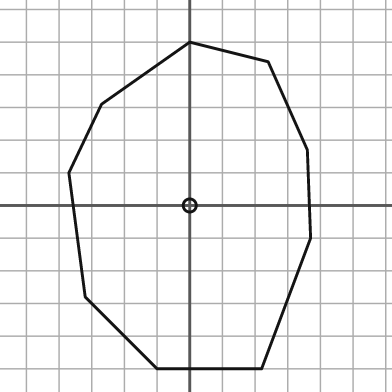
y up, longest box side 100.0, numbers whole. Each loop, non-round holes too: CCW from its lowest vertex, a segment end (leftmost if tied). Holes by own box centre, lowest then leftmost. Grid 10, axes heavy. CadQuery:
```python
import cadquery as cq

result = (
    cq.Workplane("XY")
    .moveTo(-10.0, -50.0)
    .lineTo(22.0, -50.0)
    .lineTo(37.0, -10.0)
    .lineTo(36.0, 17.0)
    .lineTo(24.0, 44.0)
    .lineTo(0.0, 50.0)
    .lineTo(-27.0, 31.0)
    .lineTo(-37.0, 10.0)
    .lineTo(-32.0, -28.0)
    .close()
    .moveTo(0.0, 0.0)
    .circle(2.0)
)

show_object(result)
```